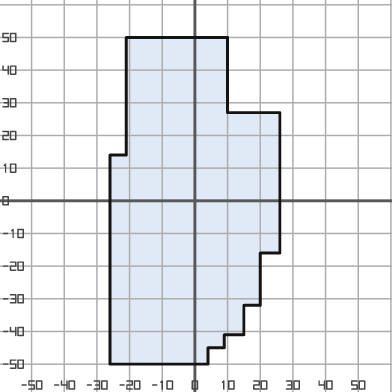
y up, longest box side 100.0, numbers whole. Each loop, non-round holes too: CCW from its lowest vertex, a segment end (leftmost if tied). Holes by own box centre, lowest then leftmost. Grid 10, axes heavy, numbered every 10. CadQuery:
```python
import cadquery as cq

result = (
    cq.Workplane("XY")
    .moveTo(-26.0, -50.0)
    .lineTo(4.0, -50.0)
    .lineTo(4.0, -45.0)
    .lineTo(9.0, -45.0)
    .lineTo(9.0, -41.0)
    .lineTo(15.0, -41.0)
    .lineTo(15.0, -32.0)
    .lineTo(20.0, -32.0)
    .lineTo(20.0, -16.0)
    .lineTo(26.0, -16.0)
    .lineTo(26.0, 27.0)
    .lineTo(10.0, 27.0)
    .lineTo(10.0, 50.0)
    .lineTo(-21.0, 50.0)
    .lineTo(-21.0, 14.0)
    .lineTo(-26.0, 14.0)
    .close()
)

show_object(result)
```